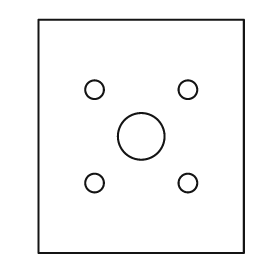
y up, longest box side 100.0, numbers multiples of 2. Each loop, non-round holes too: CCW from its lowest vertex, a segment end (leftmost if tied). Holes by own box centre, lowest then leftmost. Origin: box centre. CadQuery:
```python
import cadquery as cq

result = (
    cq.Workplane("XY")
    .moveTo(-44.0, -50.0)
    .lineTo(44.0, -50.0)
    .lineTo(44.0, 50.0)
    .lineTo(-44.0, 50.0)
    .close()
    .moveTo(-20.0, -20.0)
    .circle(4.0)
    .moveTo(20.0, -20.0)
    .circle(4.0)
    .moveTo(0.0, 0.0)
    .circle(10.0)
    .moveTo(-20.0, 20.0)
    .circle(4.0)
    .moveTo(20.0, 20.0)
    .circle(4.0)
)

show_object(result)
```